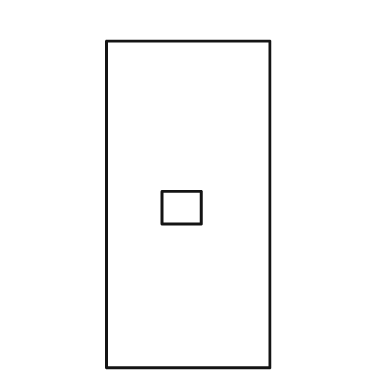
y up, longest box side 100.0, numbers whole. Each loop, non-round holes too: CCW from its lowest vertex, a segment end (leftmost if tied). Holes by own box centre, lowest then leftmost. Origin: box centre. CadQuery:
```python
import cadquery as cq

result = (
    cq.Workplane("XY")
    .moveTo(-25.0, -50.0)
    .lineTo(25.0, -50.0)
    .lineTo(25.0, 50.0)
    .lineTo(-25.0, 50.0)
    .close()
    .moveTo(-8.0, -6.0)
    .lineTo(4.0, -6.0)
    .lineTo(4.0, 4.0)
    .lineTo(-8.0, 4.0)
    .close()
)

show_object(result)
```